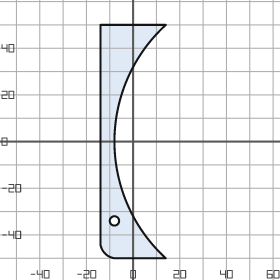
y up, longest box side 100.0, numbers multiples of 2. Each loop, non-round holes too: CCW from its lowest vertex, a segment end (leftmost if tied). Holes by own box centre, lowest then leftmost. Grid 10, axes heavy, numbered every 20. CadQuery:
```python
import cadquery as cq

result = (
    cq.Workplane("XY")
    .moveTo(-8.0, -50.0)
    .lineTo(14.0, -50.0)
    .threePointArc((-8.0, 0.0), (14.0, 50.0))
    .lineTo(-14.0, 50.0)
    .lineTo(-14.0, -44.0)
    .threePointArc((-12.0, -48.0), (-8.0, -50.0))
    .close()
    .moveTo(-8.0, -34.0)
    .circle(2.0)
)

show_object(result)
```